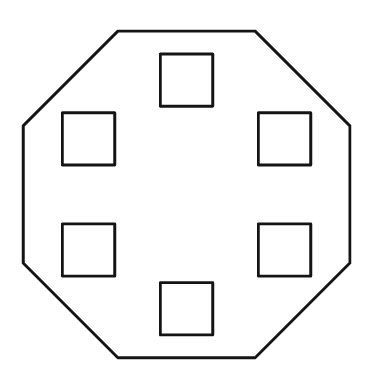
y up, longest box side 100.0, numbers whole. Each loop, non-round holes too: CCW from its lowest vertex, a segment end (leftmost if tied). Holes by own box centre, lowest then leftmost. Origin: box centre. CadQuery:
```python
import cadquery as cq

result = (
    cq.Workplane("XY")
    .moveTo(-21.0, -50.0)
    .lineTo(21.0, -50.0)
    .lineTo(50.0, -21.0)
    .lineTo(50.0, 21.0)
    .lineTo(21.0, 50.0)
    .lineTo(-21.0, 50.0)
    .lineTo(-50.0, 21.0)
    .lineTo(-50.0, -21.0)
    .close()
    .moveTo(-8.0, -43.0)
    .lineTo(8.0, -43.0)
    .lineTo(8.0, -27.0)
    .lineTo(-8.0, -27.0)
    .close()
    .moveTo(-38.0, -25.0)
    .lineTo(-22.0, -25.0)
    .lineTo(-22.0, -9.0)
    .lineTo(-38.0, -9.0)
    .close()
    .moveTo(22.0, -25.0)
    .lineTo(38.0, -25.0)
    .lineTo(38.0, -9.0)
    .lineTo(22.0, -9.0)
    .close()
    .moveTo(-38.0, 9.0)
    .lineTo(-22.0, 9.0)
    .lineTo(-22.0, 25.0)
    .lineTo(-38.0, 25.0)
    .close()
    .moveTo(22.0, 9.0)
    .lineTo(38.0, 9.0)
    .lineTo(38.0, 25.0)
    .lineTo(22.0, 25.0)
    .close()
    .moveTo(-8.0, 27.0)
    .lineTo(8.0, 27.0)
    .lineTo(8.0, 43.0)
    .lineTo(-8.0, 43.0)
    .close()
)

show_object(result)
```